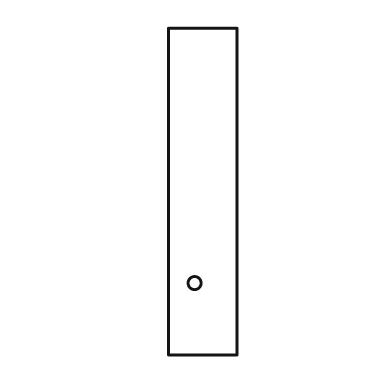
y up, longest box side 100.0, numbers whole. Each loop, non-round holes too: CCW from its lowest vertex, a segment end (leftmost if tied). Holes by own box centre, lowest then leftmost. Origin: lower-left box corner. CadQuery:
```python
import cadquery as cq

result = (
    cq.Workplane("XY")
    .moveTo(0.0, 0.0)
    .lineTo(21.0, 0.0)
    .lineTo(21.0, 100.0)
    .lineTo(0.0, 100.0)
    .close()
    .moveTo(8.0, 22.0)
    .circle(2.0)
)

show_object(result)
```